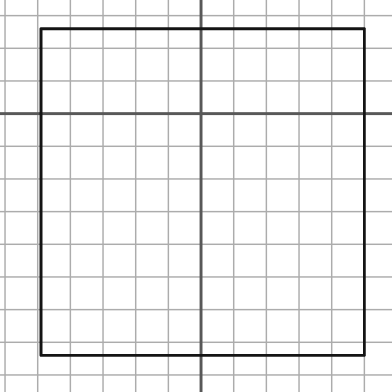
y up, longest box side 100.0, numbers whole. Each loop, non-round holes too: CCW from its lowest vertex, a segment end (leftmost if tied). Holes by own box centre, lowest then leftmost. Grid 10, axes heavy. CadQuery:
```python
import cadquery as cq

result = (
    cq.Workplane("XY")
    .moveTo(-49.0, -74.0)
    .lineTo(50.0, -74.0)
    .lineTo(50.0, 26.0)
    .lineTo(-49.0, 26.0)
    .close()
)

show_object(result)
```